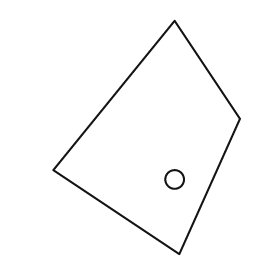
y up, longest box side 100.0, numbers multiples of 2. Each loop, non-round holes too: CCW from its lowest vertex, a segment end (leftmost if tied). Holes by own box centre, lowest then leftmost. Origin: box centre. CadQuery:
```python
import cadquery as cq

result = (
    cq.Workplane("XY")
    .moveTo(14.0, -50.0)
    .lineTo(40.0, 8.0)
    .lineTo(12.0, 50.0)
    .lineTo(-40.0, -14.0)
    .close()
    .moveTo(12.0, -18.0)
    .circle(4.0)
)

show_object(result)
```